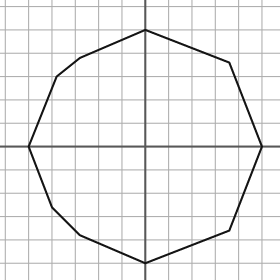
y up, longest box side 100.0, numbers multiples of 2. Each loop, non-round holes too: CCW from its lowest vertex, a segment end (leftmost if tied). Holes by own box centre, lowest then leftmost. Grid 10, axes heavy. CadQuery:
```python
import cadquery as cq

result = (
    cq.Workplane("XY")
    .moveTo(0.0, -50.0)
    .lineTo(36.0, -36.0)
    .lineTo(50.0, 0.0)
    .lineTo(36.0, 36.0)
    .lineTo(0.0, 50.0)
    .lineTo(-28.0, 38.0)
    .lineTo(-38.0, 30.0)
    .lineTo(-50.0, 0.0)
    .lineTo(-40.0, -26.0)
    .lineTo(-28.0, -38.0)
    .close()
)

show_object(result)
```